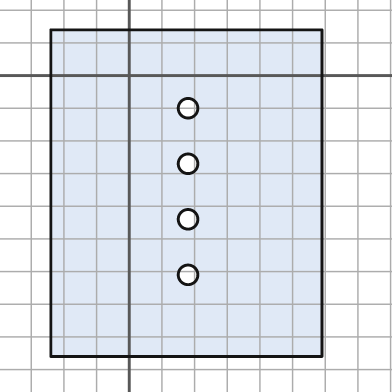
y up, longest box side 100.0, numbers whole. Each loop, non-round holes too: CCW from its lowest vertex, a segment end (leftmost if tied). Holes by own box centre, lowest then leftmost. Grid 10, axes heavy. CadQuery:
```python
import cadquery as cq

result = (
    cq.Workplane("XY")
    .moveTo(-24.0, -86.0)
    .lineTo(59.0, -86.0)
    .lineTo(59.0, 14.0)
    .lineTo(-24.0, 14.0)
    .close()
    .moveTo(18.0, -61.0)
    .circle(3.0)
    .moveTo(18.0, -44.0)
    .circle(3.0)
    .moveTo(18.0, -27.0)
    .circle(3.0)
    .moveTo(18.0, -10.0)
    .circle(3.0)
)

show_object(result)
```